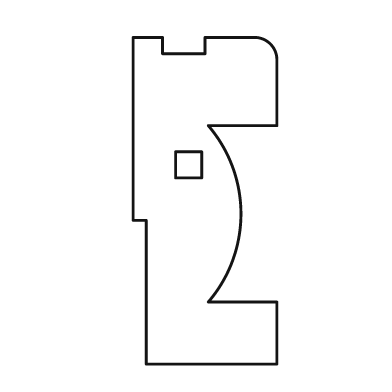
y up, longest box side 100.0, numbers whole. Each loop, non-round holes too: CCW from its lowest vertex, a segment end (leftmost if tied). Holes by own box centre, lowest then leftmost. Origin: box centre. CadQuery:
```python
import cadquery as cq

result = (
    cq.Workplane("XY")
    .moveTo(-18.0, -50.0)
    .lineTo(22.0, -50.0)
    .lineTo(22.0, -31.0)
    .lineTo(1.0, -31.0)
    .threePointArc((11.0, -4.0), (1.0, 23.0))
    .lineTo(22.0, 23.0)
    .lineTo(22.0, 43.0)
    .threePointArc((20.0, 48.0), (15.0, 50.0))
    .lineTo(0.0, 50.0)
    .lineTo(0.0, 45.0)
    .lineTo(-13.0, 45.0)
    .lineTo(-13.0, 50.0)
    .lineTo(-22.0, 50.0)
    .lineTo(-22.0, -6.0)
    .lineTo(-18.0, -6.0)
    .close()
    .moveTo(-9.0, 7.0)
    .lineTo(-1.0, 7.0)
    .lineTo(-1.0, 15.0)
    .lineTo(-9.0, 15.0)
    .close()
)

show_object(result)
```